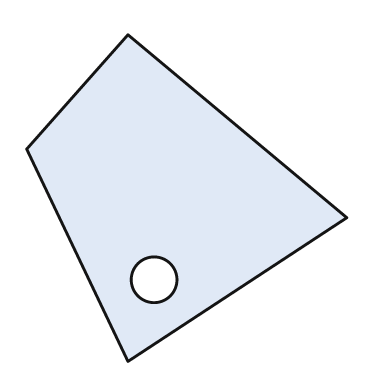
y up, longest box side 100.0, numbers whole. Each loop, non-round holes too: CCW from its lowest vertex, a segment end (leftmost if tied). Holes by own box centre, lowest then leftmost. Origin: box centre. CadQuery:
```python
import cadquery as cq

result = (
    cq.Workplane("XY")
    .moveTo(-18.0, -50.0)
    .lineTo(49.0, -6.0)
    .lineTo(-18.0, 50.0)
    .lineTo(-49.0, 15.0)
    .close()
    .moveTo(-10.0, -25.0)
    .circle(7.0)
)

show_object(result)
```